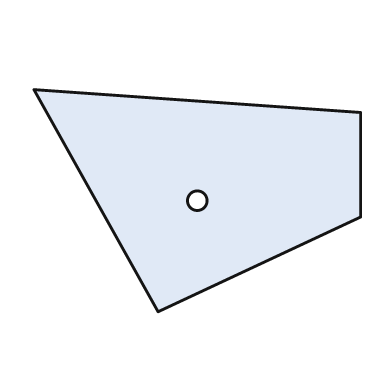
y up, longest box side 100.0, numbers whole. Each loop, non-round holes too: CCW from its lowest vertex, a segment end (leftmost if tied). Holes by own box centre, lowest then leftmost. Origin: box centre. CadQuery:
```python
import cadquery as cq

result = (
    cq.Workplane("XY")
    .moveTo(-12.0, -34.0)
    .lineTo(50.0, -5.0)
    .lineTo(50.0, 27.0)
    .lineTo(-50.0, 34.0)
    .close()
    .moveTo(0.0, 0.0)
    .circle(3.0)
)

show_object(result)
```